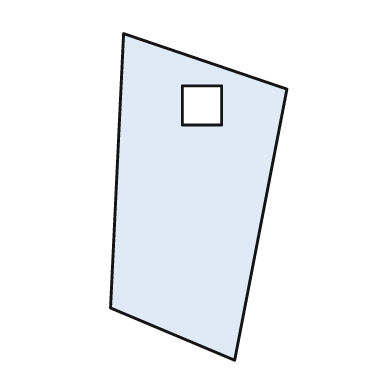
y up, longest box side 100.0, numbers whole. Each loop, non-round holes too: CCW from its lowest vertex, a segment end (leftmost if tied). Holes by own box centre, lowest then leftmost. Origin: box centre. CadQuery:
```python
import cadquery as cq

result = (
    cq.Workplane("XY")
    .moveTo(11.0, -50.0)
    .lineTo(27.0, 33.0)
    .lineTo(-23.0, 50.0)
    .lineTo(-27.0, -34.0)
    .close()
    .moveTo(-5.0, 22.0)
    .lineTo(7.0, 22.0)
    .lineTo(7.0, 34.0)
    .lineTo(-5.0, 34.0)
    .close()
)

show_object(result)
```